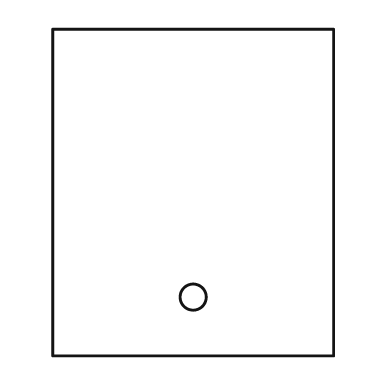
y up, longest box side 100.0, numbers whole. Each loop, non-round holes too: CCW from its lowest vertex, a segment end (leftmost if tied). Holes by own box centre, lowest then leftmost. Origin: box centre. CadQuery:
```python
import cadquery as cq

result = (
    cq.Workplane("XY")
    .moveTo(-43.0, -50.0)
    .lineTo(43.0, -50.0)
    .lineTo(43.0, 50.0)
    .lineTo(-43.0, 50.0)
    .close()
    .moveTo(0.0, -32.0)
    .circle(4.0)
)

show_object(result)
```